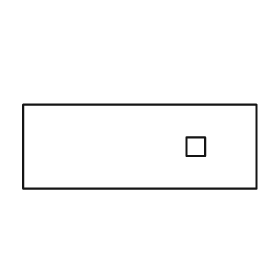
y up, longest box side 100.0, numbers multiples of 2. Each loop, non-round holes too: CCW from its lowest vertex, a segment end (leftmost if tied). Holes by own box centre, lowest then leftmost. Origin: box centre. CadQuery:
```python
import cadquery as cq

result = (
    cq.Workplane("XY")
    .moveTo(-50.0, -18.0)
    .lineTo(50.0, -18.0)
    .lineTo(50.0, 18.0)
    .lineTo(-50.0, 18.0)
    .close()
    .moveTo(20.0, -4.0)
    .lineTo(28.0, -4.0)
    .lineTo(28.0, 4.0)
    .lineTo(20.0, 4.0)
    .close()
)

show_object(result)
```